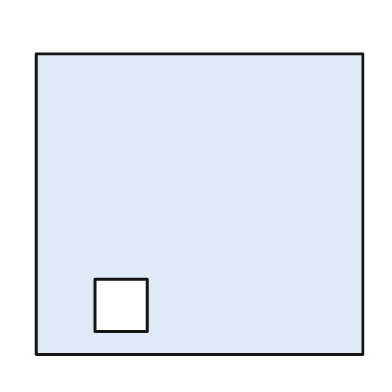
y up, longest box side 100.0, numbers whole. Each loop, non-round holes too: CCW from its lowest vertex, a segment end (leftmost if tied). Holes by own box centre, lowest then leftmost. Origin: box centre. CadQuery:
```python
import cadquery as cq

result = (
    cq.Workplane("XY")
    .moveTo(-50.0, -46.0)
    .lineTo(50.0, -46.0)
    .lineTo(50.0, 46.0)
    .lineTo(-50.0, 46.0)
    .close()
    .moveTo(-32.0, -39.0)
    .lineTo(-16.0, -39.0)
    .lineTo(-16.0, -23.0)
    .lineTo(-32.0, -23.0)
    .close()
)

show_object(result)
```